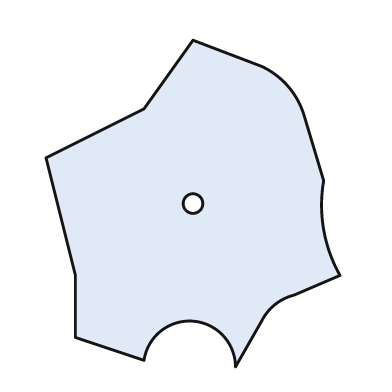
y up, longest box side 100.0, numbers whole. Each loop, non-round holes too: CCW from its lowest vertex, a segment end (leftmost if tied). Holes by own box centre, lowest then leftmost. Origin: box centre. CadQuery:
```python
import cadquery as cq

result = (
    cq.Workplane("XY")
    .moveTo(13.0, -50.0)
    .lineTo(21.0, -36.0)
    .threePointArc((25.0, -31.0), (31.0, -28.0))
    .lineTo(45.0, -22.0)
    .threePointArc((40.0, -8.0), (40.0, 7.0))
    .lineTo(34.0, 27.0)
    .threePointArc((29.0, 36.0), (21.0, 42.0))
    .lineTo(0.0, 50.0)
    .lineTo(-15.0, 29.0)
    .lineTo(-45.0, 14.0)
    .lineTo(-36.0, -22.0)
    .lineTo(-36.0, -41.0)
    .lineTo(-15.0, -48.0)
    .threePointArc((0.0, -36.0), (13.0, -50.0))
    .close()
    .moveTo(0.0, 0.0)
    .circle(3.0)
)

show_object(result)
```